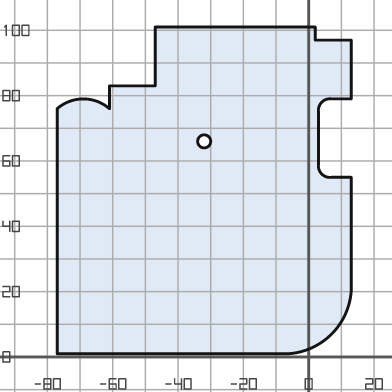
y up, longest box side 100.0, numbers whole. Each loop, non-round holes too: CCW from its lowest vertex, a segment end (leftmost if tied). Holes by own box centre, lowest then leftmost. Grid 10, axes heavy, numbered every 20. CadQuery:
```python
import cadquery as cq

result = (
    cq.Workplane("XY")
    .moveTo(-77.0, 1.0)
    .lineTo(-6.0, 1.0)
    .threePointArc((7.0, 7.0), (13.0, 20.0))
    .lineTo(13.0, 55.0)
    .lineTo(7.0, 55.0)
    .threePointArc((4.0, 56.0), (3.0, 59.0))
    .lineTo(3.0, 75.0)
    .threePointArc((4.0, 78.0), (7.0, 79.0))
    .lineTo(13.0, 79.0)
    .lineTo(13.0, 97.0)
    .lineTo(2.0, 97.0)
    .lineTo(2.0, 101.0)
    .lineTo(-47.0, 101.0)
    .lineTo(-47.0, 83.0)
    .lineTo(-61.0, 83.0)
    .lineTo(-61.0, 76.0)
    .threePointArc((-69.0, 79.0), (-77.0, 76.0))
    .close()
    .moveTo(-32.0, 66.0)
    .circle(2.0)
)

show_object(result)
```